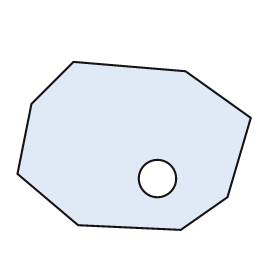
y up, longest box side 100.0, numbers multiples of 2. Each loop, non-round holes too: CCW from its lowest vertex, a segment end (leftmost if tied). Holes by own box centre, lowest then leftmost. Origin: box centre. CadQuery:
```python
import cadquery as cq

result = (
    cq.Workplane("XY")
    .moveTo(20.0, -36.0)
    .lineTo(40.0, -22.0)
    .lineTo(50.0, 12.0)
    .lineTo(22.0, 32.0)
    .lineTo(-26.0, 36.0)
    .lineTo(-44.0, 18.0)
    .lineTo(-50.0, -12.0)
    .lineTo(-24.0, -34.0)
    .close()
    .moveTo(10.0, -14.0)
    .circle(8.0)
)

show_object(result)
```